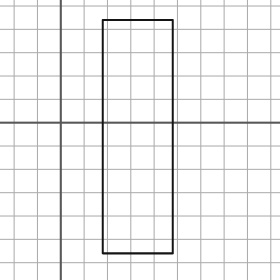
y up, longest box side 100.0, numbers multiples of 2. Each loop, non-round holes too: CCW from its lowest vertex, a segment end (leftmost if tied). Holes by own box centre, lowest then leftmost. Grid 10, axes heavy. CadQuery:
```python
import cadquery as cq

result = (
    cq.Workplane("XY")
    .moveTo(18.0, -56.0)
    .lineTo(48.0, -56.0)
    .lineTo(48.0, 44.0)
    .lineTo(18.0, 44.0)
    .close()
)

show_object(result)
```